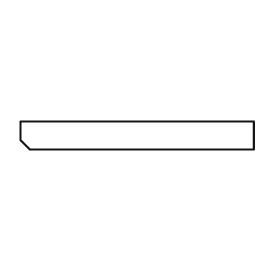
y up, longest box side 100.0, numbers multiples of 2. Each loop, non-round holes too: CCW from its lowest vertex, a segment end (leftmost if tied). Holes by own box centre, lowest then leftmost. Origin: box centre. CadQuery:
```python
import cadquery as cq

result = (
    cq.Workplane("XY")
    .moveTo(-46.0, -6.0)
    .lineTo(50.0, -6.0)
    .lineTo(50.0, 6.0)
    .lineTo(-50.0, 6.0)
    .lineTo(-50.0, -2.0)
    .close()
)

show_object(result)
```